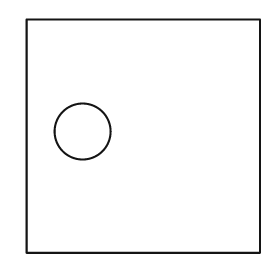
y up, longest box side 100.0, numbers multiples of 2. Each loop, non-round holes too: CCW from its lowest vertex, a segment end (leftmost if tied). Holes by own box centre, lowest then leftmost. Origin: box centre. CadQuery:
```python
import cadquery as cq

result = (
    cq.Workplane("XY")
    .moveTo(-50.0, -50.0)
    .lineTo(50.0, -50.0)
    .lineTo(50.0, 50.0)
    .lineTo(-50.0, 50.0)
    .close()
    .moveTo(-26.0, 2.0)
    .circle(12.0)
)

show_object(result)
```